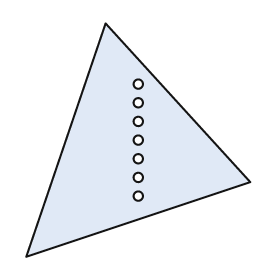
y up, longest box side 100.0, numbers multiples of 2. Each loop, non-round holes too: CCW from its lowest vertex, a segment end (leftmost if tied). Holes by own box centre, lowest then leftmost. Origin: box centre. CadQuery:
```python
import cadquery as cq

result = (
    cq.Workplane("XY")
    .moveTo(-48.0, -50.0)
    .lineTo(48.0, -18.0)
    .lineTo(-14.0, 50.0)
    .close()
    .moveTo(0.0, -24.0)
    .circle(2.0)
    .moveTo(0.0, -16.0)
    .circle(2.0)
    .moveTo(0.0, -8.0)
    .circle(2.0)
    .moveTo(0.0, 0.0)
    .circle(2.0)
    .moveTo(0.0, 8.0)
    .circle(2.0)
    .moveTo(0.0, 16.0)
    .circle(2.0)
    .moveTo(0.0, 24.0)
    .circle(2.0)
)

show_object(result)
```